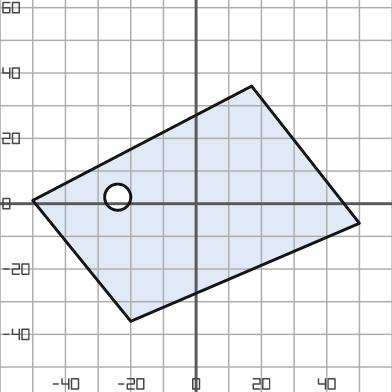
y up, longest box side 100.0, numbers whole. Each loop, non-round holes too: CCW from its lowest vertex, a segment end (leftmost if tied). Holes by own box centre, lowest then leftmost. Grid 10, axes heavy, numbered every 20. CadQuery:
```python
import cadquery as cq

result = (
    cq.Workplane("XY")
    .moveTo(-20.0, -36.0)
    .lineTo(50.0, -6.0)
    .lineTo(17.0, 36.0)
    .lineTo(-50.0, 1.0)
    .close()
    .moveTo(-24.0, 2.0)
    .circle(4.0)
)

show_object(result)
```